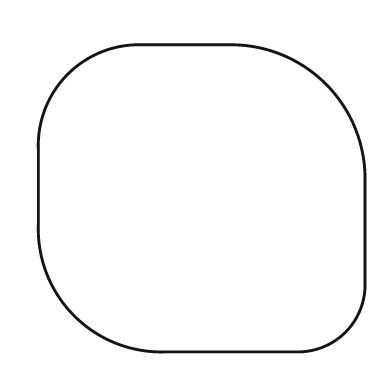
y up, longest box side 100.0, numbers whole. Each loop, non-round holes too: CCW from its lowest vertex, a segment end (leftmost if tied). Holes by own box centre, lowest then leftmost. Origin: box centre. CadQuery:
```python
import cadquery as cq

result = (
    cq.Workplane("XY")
    .moveTo(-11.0, -47.0)
    .lineTo(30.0, -47.0)
    .threePointArc((44.0, -41.0), (50.0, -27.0))
    .lineTo(50.0, 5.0)
    .threePointArc((38.0, 35.0), (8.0, 47.0))
    .lineTo(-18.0, 47.0)
    .threePointArc((-41.0, 38.0), (-50.0, 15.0))
    .lineTo(-50.0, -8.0)
    .threePointArc((-39.0, -36.0), (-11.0, -47.0))
    .close()
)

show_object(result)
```